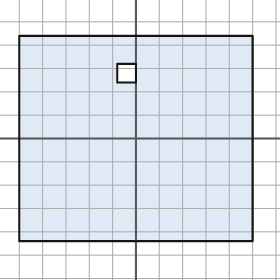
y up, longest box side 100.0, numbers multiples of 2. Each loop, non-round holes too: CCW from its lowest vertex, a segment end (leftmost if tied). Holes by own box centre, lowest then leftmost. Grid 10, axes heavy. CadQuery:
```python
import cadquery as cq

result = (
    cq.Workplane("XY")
    .moveTo(-50.0, -44.0)
    .lineTo(50.0, -44.0)
    .lineTo(50.0, 44.0)
    .lineTo(-50.0, 44.0)
    .close()
    .moveTo(-8.0, 24.0)
    .lineTo(0.0, 24.0)
    .lineTo(0.0, 32.0)
    .lineTo(-8.0, 32.0)
    .close()
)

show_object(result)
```